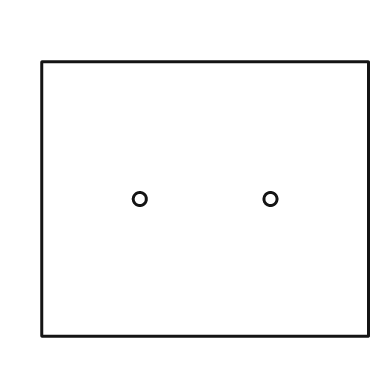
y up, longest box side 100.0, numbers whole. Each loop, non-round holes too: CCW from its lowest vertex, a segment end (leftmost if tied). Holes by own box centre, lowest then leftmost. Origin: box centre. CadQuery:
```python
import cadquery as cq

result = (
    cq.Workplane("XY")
    .moveTo(-50.0, -42.0)
    .lineTo(50.0, -42.0)
    .lineTo(50.0, 42.0)
    .lineTo(-50.0, 42.0)
    .close()
    .moveTo(-20.0, 0.0)
    .circle(2.0)
    .moveTo(20.0, 0.0)
    .circle(2.0)
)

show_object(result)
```